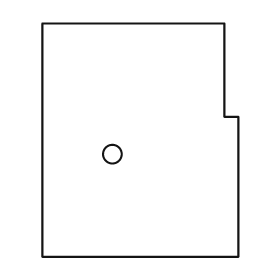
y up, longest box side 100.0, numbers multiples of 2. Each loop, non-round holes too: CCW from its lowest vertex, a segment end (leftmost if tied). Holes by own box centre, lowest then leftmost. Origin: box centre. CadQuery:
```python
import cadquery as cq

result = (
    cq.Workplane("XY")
    .moveTo(-42.0, -50.0)
    .lineTo(42.0, -50.0)
    .lineTo(42.0, 10.0)
    .lineTo(36.0, 10.0)
    .lineTo(36.0, 50.0)
    .lineTo(-42.0, 50.0)
    .close()
    .moveTo(-12.0, -6.0)
    .circle(4.0)
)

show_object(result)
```